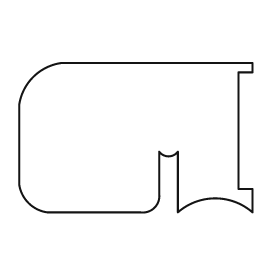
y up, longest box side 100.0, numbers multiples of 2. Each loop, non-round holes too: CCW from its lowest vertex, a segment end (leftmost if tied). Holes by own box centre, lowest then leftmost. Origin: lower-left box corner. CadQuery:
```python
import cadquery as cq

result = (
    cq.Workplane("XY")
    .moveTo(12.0, 0.0)
    .lineTo(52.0, 0.0)
    .threePointArc((58.0, 2.0), (60.0, 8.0))
    .lineTo(60.0, 26.0)
    .threePointArc((64.0, 24.0), (68.0, 26.0))
    .lineTo(68.0, 0.0)
    .threePointArc((84.0, 6.0), (100.0, 0.0))
    .lineTo(100.0, 10.0)
    .lineTo(94.0, 10.0)
    .lineTo(94.0, 60.0)
    .lineTo(100.0, 60.0)
    .lineTo(100.0, 64.0)
    .lineTo(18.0, 64.0)
    .threePointArc((6.0, 58.0), (0.0, 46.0))
    .lineTo(0.0, 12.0)
    .threePointArc((4.0, 4.0), (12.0, 0.0))
    .close()
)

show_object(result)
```